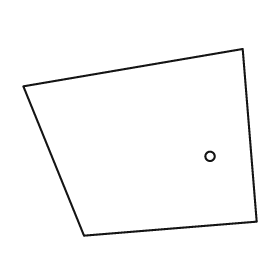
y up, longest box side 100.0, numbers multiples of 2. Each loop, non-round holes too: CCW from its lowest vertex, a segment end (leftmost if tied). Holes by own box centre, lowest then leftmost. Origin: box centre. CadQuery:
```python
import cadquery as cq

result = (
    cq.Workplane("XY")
    .moveTo(-24.0, -40.0)
    .lineTo(50.0, -34.0)
    .lineTo(44.0, 40.0)
    .lineTo(-50.0, 24.0)
    .close()
    .moveTo(30.0, -6.0)
    .circle(2.0)
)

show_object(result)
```